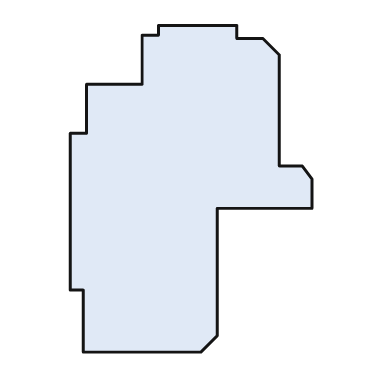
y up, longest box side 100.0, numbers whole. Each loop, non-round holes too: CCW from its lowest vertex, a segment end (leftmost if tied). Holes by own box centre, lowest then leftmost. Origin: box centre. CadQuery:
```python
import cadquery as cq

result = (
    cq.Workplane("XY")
    .moveTo(-33.0, -50.0)
    .lineTo(3.0, -50.0)
    .lineTo(8.0, -45.0)
    .lineTo(8.0, -6.0)
    .lineTo(37.0, -6.0)
    .lineTo(37.0, 3.0)
    .lineTo(34.0, 7.0)
    .lineTo(27.0, 7.0)
    .lineTo(27.0, 41.0)
    .lineTo(22.0, 46.0)
    .lineTo(14.0, 46.0)
    .lineTo(14.0, 50.0)
    .lineTo(-10.0, 50.0)
    .lineTo(-10.0, 47.0)
    .lineTo(-15.0, 47.0)
    .lineTo(-15.0, 32.0)
    .lineTo(-32.0, 32.0)
    .lineTo(-32.0, 17.0)
    .lineTo(-37.0, 17.0)
    .lineTo(-37.0, -31.0)
    .lineTo(-33.0, -31.0)
    .close()
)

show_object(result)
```